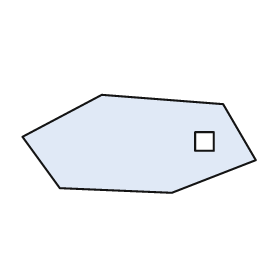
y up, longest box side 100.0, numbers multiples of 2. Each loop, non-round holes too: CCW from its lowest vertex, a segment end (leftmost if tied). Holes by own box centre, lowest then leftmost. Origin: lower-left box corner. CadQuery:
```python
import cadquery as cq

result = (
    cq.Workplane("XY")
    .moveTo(64.0, 0.0)
    .lineTo(100.0, 14.0)
    .lineTo(86.0, 38.0)
    .lineTo(34.0, 42.0)
    .lineTo(0.0, 24.0)
    .lineTo(16.0, 2.0)
    .close()
    .moveTo(74.0, 18.0)
    .lineTo(82.0, 18.0)
    .lineTo(82.0, 26.0)
    .lineTo(74.0, 26.0)
    .close()
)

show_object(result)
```